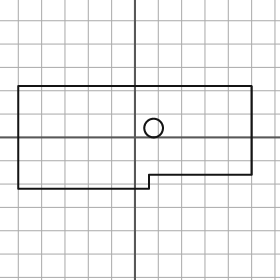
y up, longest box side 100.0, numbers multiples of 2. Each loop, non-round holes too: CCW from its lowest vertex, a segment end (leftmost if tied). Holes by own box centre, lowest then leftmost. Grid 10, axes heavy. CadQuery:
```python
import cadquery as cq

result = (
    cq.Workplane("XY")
    .moveTo(-50.0, -22.0)
    .lineTo(6.0, -22.0)
    .lineTo(6.0, -16.0)
    .lineTo(50.0, -16.0)
    .lineTo(50.0, 22.0)
    .lineTo(-50.0, 22.0)
    .close()
    .moveTo(8.0, 4.0)
    .circle(4.0)
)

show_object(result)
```